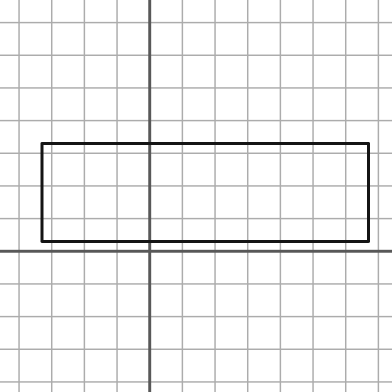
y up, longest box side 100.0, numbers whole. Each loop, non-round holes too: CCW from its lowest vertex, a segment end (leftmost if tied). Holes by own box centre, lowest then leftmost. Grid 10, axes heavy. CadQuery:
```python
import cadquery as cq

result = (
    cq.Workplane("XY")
    .moveTo(-33.0, 3.0)
    .lineTo(67.0, 3.0)
    .lineTo(67.0, 33.0)
    .lineTo(-33.0, 33.0)
    .close()
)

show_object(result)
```